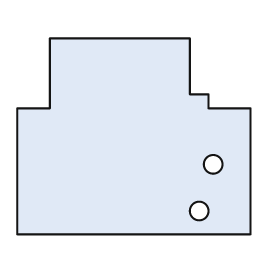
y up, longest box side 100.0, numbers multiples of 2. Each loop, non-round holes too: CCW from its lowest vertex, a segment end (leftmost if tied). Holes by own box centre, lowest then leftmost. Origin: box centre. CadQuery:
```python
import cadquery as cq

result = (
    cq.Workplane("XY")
    .moveTo(-50.0, -42.0)
    .lineTo(50.0, -42.0)
    .lineTo(50.0, 12.0)
    .lineTo(32.0, 12.0)
    .lineTo(32.0, 18.0)
    .lineTo(24.0, 18.0)
    .lineTo(24.0, 42.0)
    .lineTo(-36.0, 42.0)
    .lineTo(-36.0, 12.0)
    .lineTo(-50.0, 12.0)
    .close()
    .moveTo(28.0, -32.0)
    .circle(4.0)
    .moveTo(34.0, -12.0)
    .circle(4.0)
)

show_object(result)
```